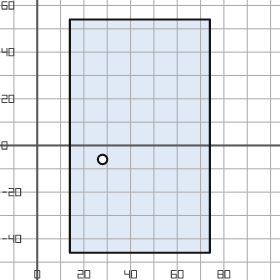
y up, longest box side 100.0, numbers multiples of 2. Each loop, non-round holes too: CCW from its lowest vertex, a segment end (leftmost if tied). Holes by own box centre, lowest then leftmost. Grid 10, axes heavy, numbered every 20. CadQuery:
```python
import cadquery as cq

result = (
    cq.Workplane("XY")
    .moveTo(14.0, -46.0)
    .lineTo(74.0, -46.0)
    .lineTo(74.0, 54.0)
    .lineTo(14.0, 54.0)
    .close()
    .moveTo(28.0, -6.0)
    .circle(2.0)
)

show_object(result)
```